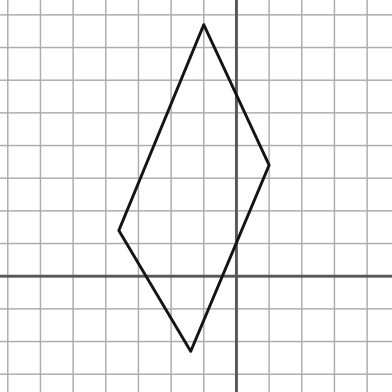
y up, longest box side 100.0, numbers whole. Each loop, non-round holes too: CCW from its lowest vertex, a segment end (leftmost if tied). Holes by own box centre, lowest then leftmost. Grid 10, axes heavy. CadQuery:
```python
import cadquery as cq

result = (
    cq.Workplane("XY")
    .moveTo(-14.0, -23.0)
    .lineTo(10.0, 34.0)
    .lineTo(-10.0, 77.0)
    .lineTo(-36.0, 14.0)
    .close()
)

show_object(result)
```